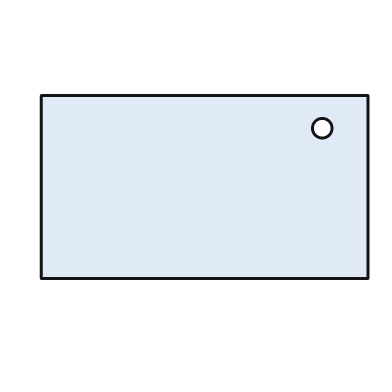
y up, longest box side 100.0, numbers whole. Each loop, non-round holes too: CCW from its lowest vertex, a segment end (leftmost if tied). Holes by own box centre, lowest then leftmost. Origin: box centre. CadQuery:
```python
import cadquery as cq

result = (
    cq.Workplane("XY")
    .moveTo(-50.0, -28.0)
    .lineTo(50.0, -28.0)
    .lineTo(50.0, 28.0)
    .lineTo(-50.0, 28.0)
    .close()
    .moveTo(36.0, 18.0)
    .circle(3.0)
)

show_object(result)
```